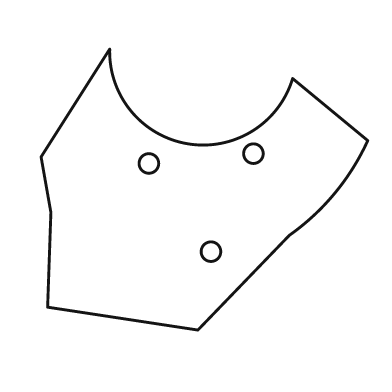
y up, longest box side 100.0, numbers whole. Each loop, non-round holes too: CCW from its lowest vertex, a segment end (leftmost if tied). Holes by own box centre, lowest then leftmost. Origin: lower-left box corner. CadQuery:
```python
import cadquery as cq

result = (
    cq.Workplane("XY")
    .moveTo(48.0, 0.0)
    .lineTo(76.0, 29.0)
    .threePointArc((90.0, 42.0), (100.0, 58.0))
    .lineTo(77.0, 77.0)
    .threePointArc((45.0, 57.0), (21.0, 86.0))
    .lineTo(0.0, 53.0)
    .lineTo(3.0, 36.0)
    .lineTo(2.0, 7.0)
    .close()
    .moveTo(52.0, 24.0)
    .circle(3.0)
    .moveTo(33.0, 51.0)
    .circle(3.0)
    .moveTo(65.0, 54.0)
    .circle(3.0)
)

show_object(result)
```